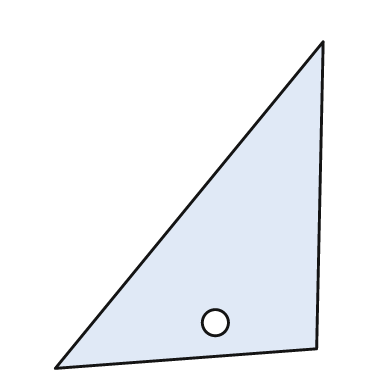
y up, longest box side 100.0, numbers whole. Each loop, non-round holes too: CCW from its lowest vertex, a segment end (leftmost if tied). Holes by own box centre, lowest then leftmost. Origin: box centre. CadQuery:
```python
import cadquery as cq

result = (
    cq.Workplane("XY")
    .moveTo(-41.0, -50.0)
    .lineTo(39.0, -44.0)
    .lineTo(41.0, 50.0)
    .close()
    .moveTo(8.0, -36.0)
    .circle(4.0)
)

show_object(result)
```